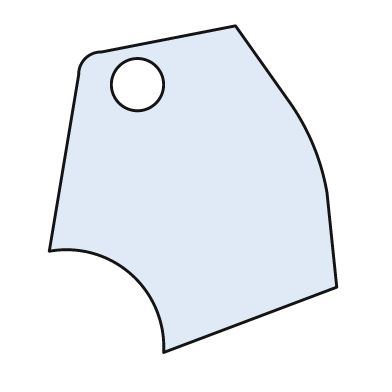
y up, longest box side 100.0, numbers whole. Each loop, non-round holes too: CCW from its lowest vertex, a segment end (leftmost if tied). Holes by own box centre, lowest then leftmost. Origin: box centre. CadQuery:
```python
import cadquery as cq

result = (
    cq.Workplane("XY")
    .moveTo(-9.0, -50.0)
    .lineTo(44.0, -30.0)
    .lineTo(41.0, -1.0)
    .threePointArc((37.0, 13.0), (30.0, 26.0))
    .lineTo(13.0, 50.0)
    .lineTo(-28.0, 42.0)
    .threePointArc((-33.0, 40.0), (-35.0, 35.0))
    .lineTo(-44.0, -19.0)
    .threePointArc((-19.0, -26.0), (-9.0, -50.0))
    .close()
    .moveTo(-17.0, 32.0)
    .circle(8.0)
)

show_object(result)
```